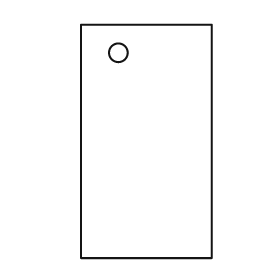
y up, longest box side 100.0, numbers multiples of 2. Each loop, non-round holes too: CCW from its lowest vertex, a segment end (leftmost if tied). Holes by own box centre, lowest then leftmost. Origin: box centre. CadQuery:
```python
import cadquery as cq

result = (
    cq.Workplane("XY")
    .moveTo(-28.0, -50.0)
    .lineTo(28.0, -50.0)
    .lineTo(28.0, 50.0)
    .lineTo(-28.0, 50.0)
    .close()
    .moveTo(-12.0, 38.0)
    .circle(4.0)
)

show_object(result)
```